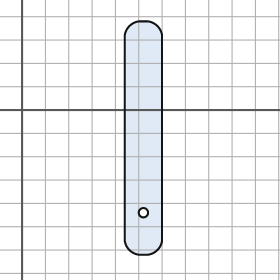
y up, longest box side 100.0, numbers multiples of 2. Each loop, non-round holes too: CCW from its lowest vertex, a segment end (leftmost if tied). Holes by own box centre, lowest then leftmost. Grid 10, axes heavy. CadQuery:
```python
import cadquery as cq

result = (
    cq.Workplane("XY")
    .moveTo(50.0, -62.0)
    .lineTo(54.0, -62.0)
    .threePointArc((58.0, -60.0), (60.0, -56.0))
    .lineTo(60.0, 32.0)
    .threePointArc((58.0, 36.0), (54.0, 38.0))
    .lineTo(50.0, 38.0)
    .threePointArc((46.0, 36.0), (44.0, 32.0))
    .lineTo(44.0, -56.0)
    .threePointArc((46.0, -60.0), (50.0, -62.0))
    .close()
    .moveTo(52.0, -44.0)
    .circle(2.0)
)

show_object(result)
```